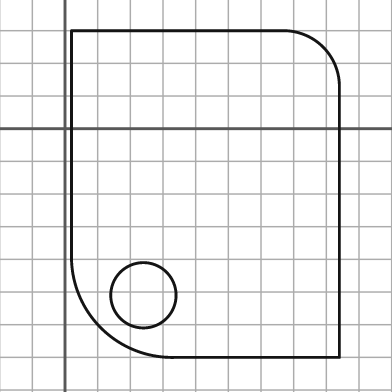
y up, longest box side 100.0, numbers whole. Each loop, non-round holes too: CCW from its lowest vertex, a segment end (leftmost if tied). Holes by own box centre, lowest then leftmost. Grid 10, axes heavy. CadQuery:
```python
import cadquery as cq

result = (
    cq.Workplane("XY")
    .moveTo(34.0, -70.0)
    .lineTo(84.0, -70.0)
    .lineTo(84.0, 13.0)
    .threePointArc((79.0, 25.0), (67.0, 30.0))
    .lineTo(2.0, 30.0)
    .lineTo(2.0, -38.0)
    .threePointArc((11.0, -61.0), (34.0, -70.0))
    .close()
    .moveTo(24.0, -51.0)
    .circle(10.0)
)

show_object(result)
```